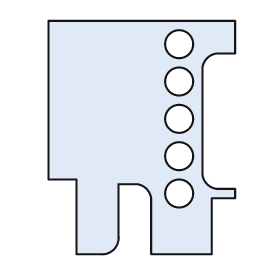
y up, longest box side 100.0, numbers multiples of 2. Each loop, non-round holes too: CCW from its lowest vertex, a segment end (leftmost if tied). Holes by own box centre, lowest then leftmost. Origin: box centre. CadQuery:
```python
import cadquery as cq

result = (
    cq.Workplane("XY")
    .moveTo(-28.0, -50.0)
    .lineTo(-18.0, -50.0)
    .threePointArc((-12.0, -48.0), (-10.0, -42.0))
    .lineTo(-10.0, -20.0)
    .lineTo(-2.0, -20.0)
    .threePointArc((2.0, -22.0), (4.0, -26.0))
    .lineTo(4.0, -50.0)
    .lineTo(30.0, -50.0)
    .lineTo(30.0, -26.0)
    .lineTo(40.0, -26.0)
    .lineTo(40.0, -22.0)
    .lineTo(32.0, -22.0)
    .threePointArc((28.0, -20.0), (26.0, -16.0))
    .lineTo(26.0, 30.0)
    .threePointArc((28.0, 34.0), (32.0, 36.0))
    .lineTo(40.0, 36.0)
    .lineTo(40.0, 50.0)
    .lineTo(-40.0, 50.0)
    .lineTo(-40.0, -18.0)
    .lineTo(-28.0, -18.0)
    .close()
    .moveTo(16.0, -24.0)
    .circle(6.0)
    .moveTo(16.0, -8.0)
    .circle(6.0)
    .moveTo(16.0, 8.0)
    .circle(6.0)
    .moveTo(16.0, 24.0)
    .circle(6.0)
    .moveTo(16.0, 40.0)
    .circle(6.0)
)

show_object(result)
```